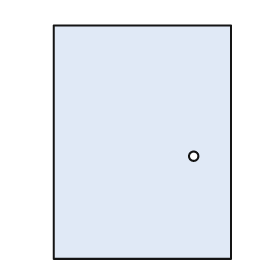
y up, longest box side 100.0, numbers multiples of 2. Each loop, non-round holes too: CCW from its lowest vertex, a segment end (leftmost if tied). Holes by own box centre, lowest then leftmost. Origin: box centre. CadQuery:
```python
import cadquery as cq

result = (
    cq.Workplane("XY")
    .moveTo(-38.0, -50.0)
    .lineTo(38.0, -50.0)
    .lineTo(38.0, 50.0)
    .lineTo(-38.0, 50.0)
    .close()
    .moveTo(22.0, -6.0)
    .circle(2.0)
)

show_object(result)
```